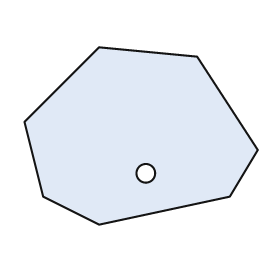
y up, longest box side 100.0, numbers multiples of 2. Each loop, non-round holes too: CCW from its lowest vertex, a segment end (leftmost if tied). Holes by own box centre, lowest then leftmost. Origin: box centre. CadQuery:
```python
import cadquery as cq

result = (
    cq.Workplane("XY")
    .moveTo(-18.0, -38.0)
    .lineTo(38.0, -26.0)
    .lineTo(50.0, -6.0)
    .lineTo(24.0, 34.0)
    .lineTo(-18.0, 38.0)
    .lineTo(-50.0, 6.0)
    .lineTo(-42.0, -26.0)
    .close()
    .moveTo(2.0, -16.0)
    .circle(4.0)
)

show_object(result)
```